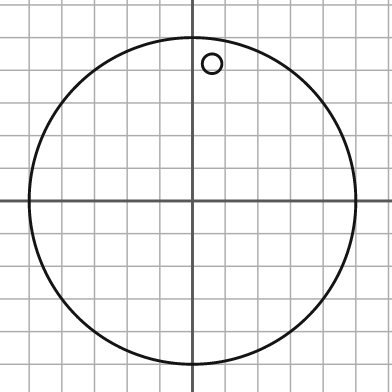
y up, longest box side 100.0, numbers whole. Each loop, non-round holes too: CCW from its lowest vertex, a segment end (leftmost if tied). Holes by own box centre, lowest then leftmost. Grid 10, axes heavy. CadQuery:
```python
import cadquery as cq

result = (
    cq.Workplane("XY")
    .moveTo(0.0, 0.0)
    .circle(50.0)
    .moveTo(6.0, 42.0)
    .circle(3.0)
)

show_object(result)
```